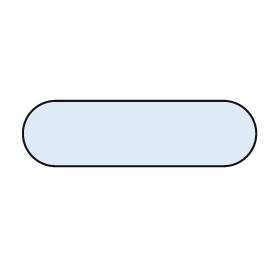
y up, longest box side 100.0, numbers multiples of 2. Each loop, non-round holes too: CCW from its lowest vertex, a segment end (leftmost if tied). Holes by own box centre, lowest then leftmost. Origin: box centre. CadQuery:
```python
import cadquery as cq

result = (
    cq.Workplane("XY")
    .moveTo(-36.0, -14.0)
    .lineTo(36.0, -14.0)
    .threePointArc((50.0, 0.0), (36.0, 14.0))
    .lineTo(-36.0, 14.0)
    .threePointArc((-50.0, 0.0), (-36.0, -14.0))
    .close()
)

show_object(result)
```